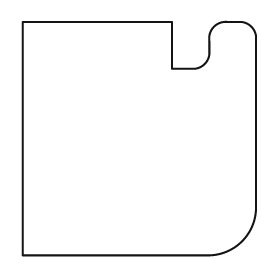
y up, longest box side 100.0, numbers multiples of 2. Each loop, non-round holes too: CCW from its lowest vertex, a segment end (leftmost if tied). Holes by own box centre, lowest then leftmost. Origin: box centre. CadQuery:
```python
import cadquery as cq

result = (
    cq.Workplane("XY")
    .moveTo(-50.0, -50.0)
    .lineTo(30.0, -50.0)
    .threePointArc((44.0, -44.0), (50.0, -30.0))
    .lineTo(50.0, 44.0)
    .threePointArc((48.0, 48.0), (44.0, 50.0))
    .lineTo(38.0, 50.0)
    .threePointArc((32.0, 48.0), (30.0, 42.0))
    .lineTo(30.0, 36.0)
    .threePointArc((28.0, 32.0), (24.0, 30.0))
    .lineTo(14.0, 30.0)
    .lineTo(14.0, 50.0)
    .lineTo(-50.0, 50.0)
    .close()
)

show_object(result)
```